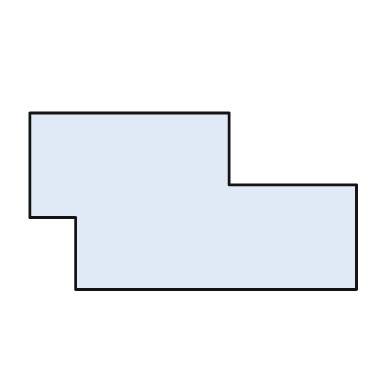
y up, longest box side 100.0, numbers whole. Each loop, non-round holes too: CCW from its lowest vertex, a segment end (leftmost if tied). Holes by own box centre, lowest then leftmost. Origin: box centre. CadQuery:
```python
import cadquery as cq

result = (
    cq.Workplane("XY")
    .moveTo(-36.0, -27.0)
    .lineTo(50.0, -27.0)
    .lineTo(50.0, 5.0)
    .lineTo(11.0, 5.0)
    .lineTo(11.0, 27.0)
    .lineTo(-50.0, 27.0)
    .lineTo(-50.0, -5.0)
    .lineTo(-36.0, -5.0)
    .close()
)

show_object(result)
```